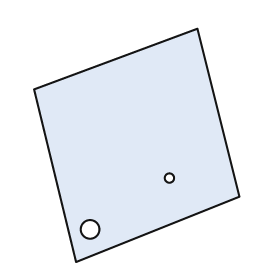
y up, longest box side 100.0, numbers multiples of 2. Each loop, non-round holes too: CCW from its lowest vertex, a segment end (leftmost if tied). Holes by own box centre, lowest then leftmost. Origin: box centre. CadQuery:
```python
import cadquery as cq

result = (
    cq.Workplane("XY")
    .moveTo(-26.0, -50.0)
    .lineTo(44.0, -22.0)
    .lineTo(26.0, 50.0)
    .lineTo(-44.0, 24.0)
    .close()
    .moveTo(-20.0, -36.0)
    .circle(4.0)
    .moveTo(14.0, -14.0)
    .circle(2.0)
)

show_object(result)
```